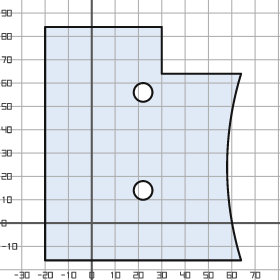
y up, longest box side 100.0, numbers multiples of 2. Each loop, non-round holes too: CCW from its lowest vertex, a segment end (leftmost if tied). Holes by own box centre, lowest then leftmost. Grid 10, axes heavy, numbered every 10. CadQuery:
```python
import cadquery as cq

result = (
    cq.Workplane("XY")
    .moveTo(-20.0, -16.0)
    .lineTo(64.0, -16.0)
    .threePointArc((58.0, 24.0), (64.0, 64.0))
    .lineTo(30.0, 64.0)
    .lineTo(30.0, 84.0)
    .lineTo(-20.0, 84.0)
    .close()
    .moveTo(22.0, 14.0)
    .circle(4.0)
    .moveTo(22.0, 56.0)
    .circle(4.0)
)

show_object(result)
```